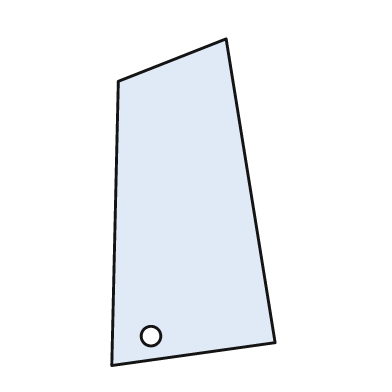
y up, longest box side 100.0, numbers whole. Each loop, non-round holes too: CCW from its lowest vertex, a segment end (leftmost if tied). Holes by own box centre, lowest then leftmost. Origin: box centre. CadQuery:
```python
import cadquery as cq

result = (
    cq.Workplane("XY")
    .moveTo(-25.0, -50.0)
    .lineTo(25.0, -43.0)
    .lineTo(10.0, 50.0)
    .lineTo(-23.0, 37.0)
    .close()
    .moveTo(-13.0, -41.0)
    .circle(3.0)
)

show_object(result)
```